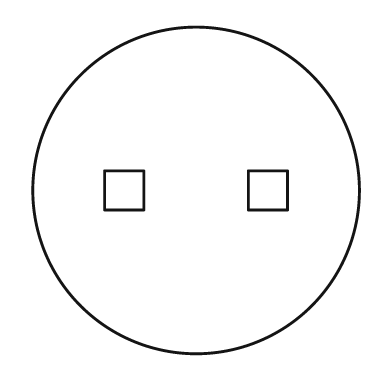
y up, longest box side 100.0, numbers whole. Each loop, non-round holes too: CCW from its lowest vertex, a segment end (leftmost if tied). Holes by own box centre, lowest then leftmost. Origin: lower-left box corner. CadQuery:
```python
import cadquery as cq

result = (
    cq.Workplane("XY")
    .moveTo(50.0, 50.0)
    .circle(50.0)
    .moveTo(22.0, 44.0)
    .lineTo(34.0, 44.0)
    .lineTo(34.0, 56.0)
    .lineTo(22.0, 56.0)
    .close()
    .moveTo(66.0, 44.0)
    .lineTo(78.0, 44.0)
    .lineTo(78.0, 56.0)
    .lineTo(66.0, 56.0)
    .close()
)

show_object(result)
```